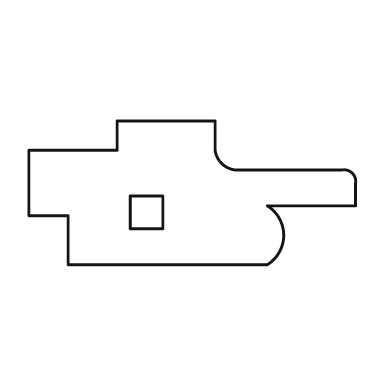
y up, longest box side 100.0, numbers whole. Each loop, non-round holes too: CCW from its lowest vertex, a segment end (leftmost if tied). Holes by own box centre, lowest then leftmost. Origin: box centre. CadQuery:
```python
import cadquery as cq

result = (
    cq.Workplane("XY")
    .moveTo(-38.0, -22.0)
    .lineTo(23.0, -22.0)
    .threePointArc((28.0, -13.0), (23.0, -4.0))
    .lineTo(50.0, -4.0)
    .lineTo(50.0, 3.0)
    .threePointArc((49.0, 6.0), (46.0, 7.0))
    .lineTo(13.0, 7.0)
    .threePointArc((9.0, 9.0), (7.0, 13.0))
    .lineTo(7.0, 22.0)
    .lineTo(-23.0, 22.0)
    .lineTo(-23.0, 13.0)
    .lineTo(-50.0, 13.0)
    .lineTo(-50.0, -7.0)
    .lineTo(-38.0, -7.0)
    .close()
    .moveTo(-19.0, -11.0)
    .lineTo(-9.0, -11.0)
    .lineTo(-9.0, -1.0)
    .lineTo(-19.0, -1.0)
    .close()
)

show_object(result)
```